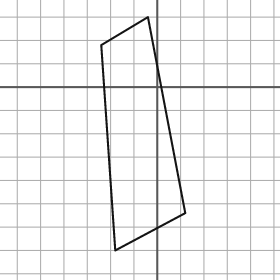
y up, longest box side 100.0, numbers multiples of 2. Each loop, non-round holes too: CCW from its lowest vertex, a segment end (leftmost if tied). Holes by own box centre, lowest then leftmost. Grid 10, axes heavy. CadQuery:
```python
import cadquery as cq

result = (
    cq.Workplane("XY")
    .moveTo(-18.0, -70.0)
    .lineTo(12.0, -54.0)
    .lineTo(-4.0, 30.0)
    .lineTo(-24.0, 18.0)
    .close()
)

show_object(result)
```